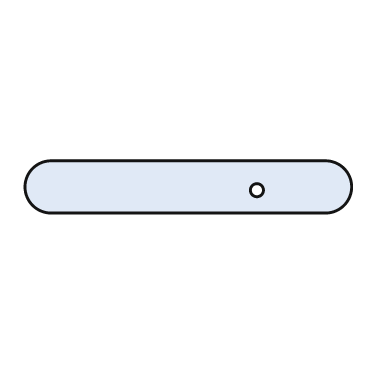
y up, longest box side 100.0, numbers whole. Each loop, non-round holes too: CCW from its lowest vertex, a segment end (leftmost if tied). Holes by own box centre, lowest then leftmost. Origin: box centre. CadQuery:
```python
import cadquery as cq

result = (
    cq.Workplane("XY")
    .moveTo(-42.0, -8.0)
    .lineTo(42.0, -8.0)
    .threePointArc((50.0, 0.0), (42.0, 8.0))
    .lineTo(-42.0, 8.0)
    .threePointArc((-50.0, 0.0), (-42.0, -8.0))
    .close()
    .moveTo(21.0, -1.0)
    .circle(2.0)
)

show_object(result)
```